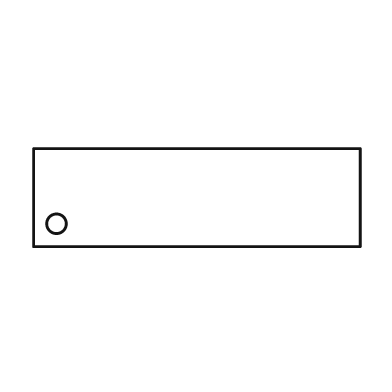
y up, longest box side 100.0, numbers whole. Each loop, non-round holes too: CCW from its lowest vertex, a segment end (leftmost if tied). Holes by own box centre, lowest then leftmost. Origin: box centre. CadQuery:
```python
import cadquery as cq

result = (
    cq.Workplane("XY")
    .moveTo(-50.0, -15.0)
    .lineTo(50.0, -15.0)
    .lineTo(50.0, 15.0)
    .lineTo(-50.0, 15.0)
    .close()
    .moveTo(-43.0, -8.0)
    .circle(3.0)
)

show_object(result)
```